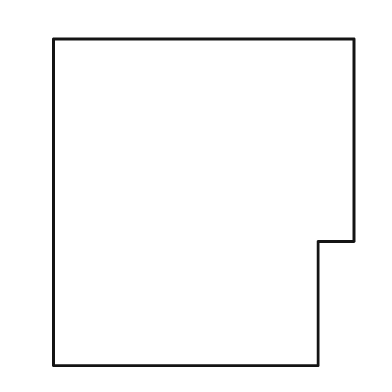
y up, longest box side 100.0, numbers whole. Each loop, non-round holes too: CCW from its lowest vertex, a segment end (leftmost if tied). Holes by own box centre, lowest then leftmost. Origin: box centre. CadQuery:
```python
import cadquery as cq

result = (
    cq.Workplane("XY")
    .moveTo(-46.0, -50.0)
    .lineTo(35.0, -50.0)
    .lineTo(35.0, -12.0)
    .lineTo(46.0, -12.0)
    .lineTo(46.0, 50.0)
    .lineTo(-46.0, 50.0)
    .close()
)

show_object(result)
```